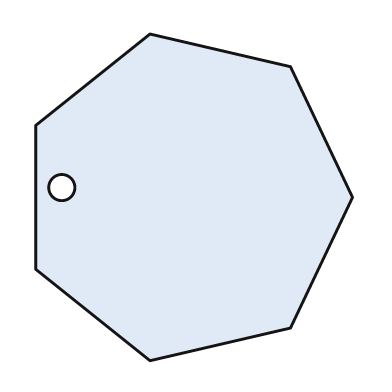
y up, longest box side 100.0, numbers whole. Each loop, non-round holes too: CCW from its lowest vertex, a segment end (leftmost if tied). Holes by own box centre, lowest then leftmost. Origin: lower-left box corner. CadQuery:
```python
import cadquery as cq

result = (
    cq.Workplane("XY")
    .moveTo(35.0, 0.0)
    .lineTo(78.0, 10.0)
    .lineTo(97.0, 50.0)
    .lineTo(78.0, 90.0)
    .lineTo(35.0, 100.0)
    .lineTo(0.0, 72.0)
    .lineTo(0.0, 28.0)
    .close()
    .moveTo(8.0, 53.0)
    .circle(4.0)
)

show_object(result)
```